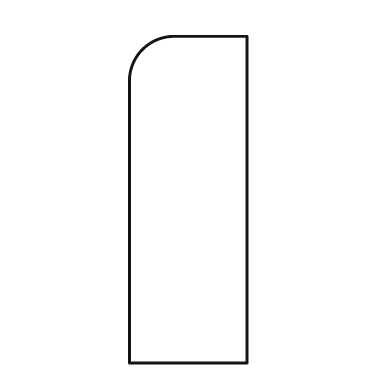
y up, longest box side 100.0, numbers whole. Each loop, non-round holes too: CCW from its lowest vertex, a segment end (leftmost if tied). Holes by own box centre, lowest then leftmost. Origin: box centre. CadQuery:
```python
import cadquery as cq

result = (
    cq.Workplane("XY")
    .moveTo(-18.0, -50.0)
    .lineTo(18.0, -50.0)
    .lineTo(18.0, 50.0)
    .lineTo(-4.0, 50.0)
    .threePointArc((-14.0, 46.0), (-18.0, 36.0))
    .close()
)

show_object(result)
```